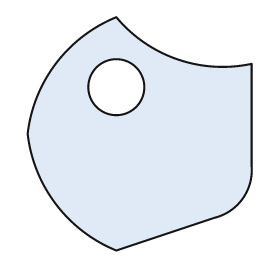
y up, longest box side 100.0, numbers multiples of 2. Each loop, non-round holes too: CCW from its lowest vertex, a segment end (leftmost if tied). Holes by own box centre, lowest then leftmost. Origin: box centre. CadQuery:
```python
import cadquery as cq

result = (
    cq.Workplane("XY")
    .moveTo(-10.0, -50.0)
    .lineTo(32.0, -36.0)
    .threePointArc((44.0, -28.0), (48.0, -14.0))
    .lineTo(48.0, 30.0)
    .threePointArc((16.0, 32.0), (-10.0, 50.0))
    .threePointArc((-36.0, 30.0), (-48.0, 0.0))
    .threePointArc((-36.0, -30.0), (-10.0, -50.0))
    .close()
    .moveTo(-10.0, 20.0)
    .circle(12.0)
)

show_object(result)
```